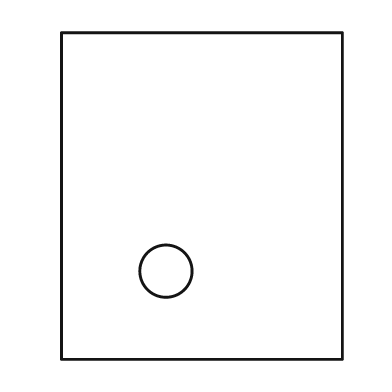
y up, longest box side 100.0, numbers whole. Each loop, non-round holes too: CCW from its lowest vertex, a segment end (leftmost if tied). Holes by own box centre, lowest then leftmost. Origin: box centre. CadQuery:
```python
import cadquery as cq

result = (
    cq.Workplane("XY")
    .moveTo(-43.0, -50.0)
    .lineTo(43.0, -50.0)
    .lineTo(43.0, 50.0)
    .lineTo(-43.0, 50.0)
    .close()
    .moveTo(-11.0, -23.0)
    .circle(8.0)
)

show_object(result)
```